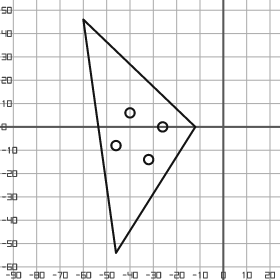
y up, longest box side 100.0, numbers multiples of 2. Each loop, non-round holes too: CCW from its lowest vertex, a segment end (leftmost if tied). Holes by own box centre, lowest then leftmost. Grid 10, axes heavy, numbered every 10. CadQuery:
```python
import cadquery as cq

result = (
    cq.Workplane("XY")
    .moveTo(-46.0, -54.0)
    .lineTo(-12.0, 0.0)
    .lineTo(-60.0, 46.0)
    .close()
    .moveTo(-32.0, -14.0)
    .circle(2.0)
    .moveTo(-46.0, -8.0)
    .circle(2.0)
    .moveTo(-26.0, 0.0)
    .circle(2.0)
    .moveTo(-40.0, 6.0)
    .circle(2.0)
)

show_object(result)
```